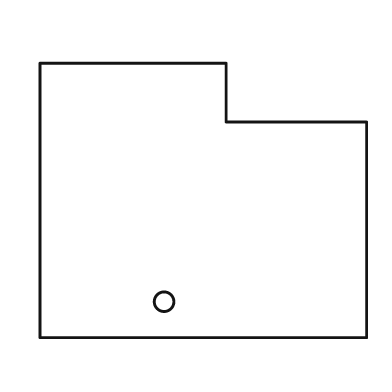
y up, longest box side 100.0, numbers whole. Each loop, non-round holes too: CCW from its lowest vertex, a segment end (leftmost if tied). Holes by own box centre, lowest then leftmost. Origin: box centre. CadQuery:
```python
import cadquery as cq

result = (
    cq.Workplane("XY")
    .moveTo(-50.0, -42.0)
    .lineTo(50.0, -42.0)
    .lineTo(50.0, 24.0)
    .lineTo(7.0, 24.0)
    .lineTo(7.0, 42.0)
    .lineTo(-50.0, 42.0)
    .close()
    .moveTo(-12.0, -31.0)
    .circle(3.0)
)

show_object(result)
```